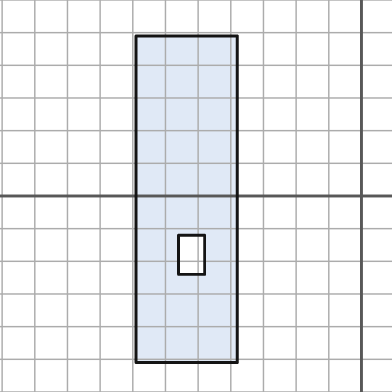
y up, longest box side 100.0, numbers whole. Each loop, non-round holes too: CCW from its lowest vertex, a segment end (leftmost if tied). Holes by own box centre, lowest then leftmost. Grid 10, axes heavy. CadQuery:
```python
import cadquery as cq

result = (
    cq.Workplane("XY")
    .moveTo(-69.0, -51.0)
    .lineTo(-38.0, -51.0)
    .lineTo(-38.0, 49.0)
    .lineTo(-69.0, 49.0)
    .close()
    .moveTo(-56.0, -24.0)
    .lineTo(-48.0, -24.0)
    .lineTo(-48.0, -12.0)
    .lineTo(-56.0, -12.0)
    .close()
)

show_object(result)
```